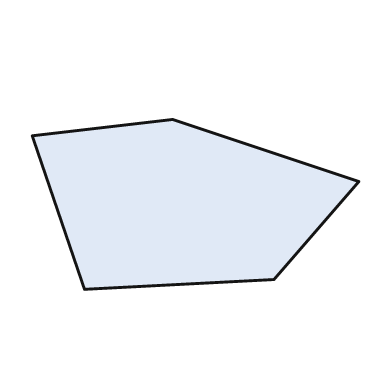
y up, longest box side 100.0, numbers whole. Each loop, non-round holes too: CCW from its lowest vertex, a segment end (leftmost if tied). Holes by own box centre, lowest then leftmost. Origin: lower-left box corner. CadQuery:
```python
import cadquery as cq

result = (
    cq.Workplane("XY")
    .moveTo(16.0, 0.0)
    .lineTo(74.0, 3.0)
    .lineTo(100.0, 33.0)
    .lineTo(43.0, 52.0)
    .lineTo(0.0, 47.0)
    .close()
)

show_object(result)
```